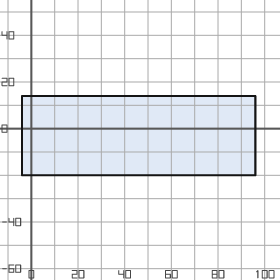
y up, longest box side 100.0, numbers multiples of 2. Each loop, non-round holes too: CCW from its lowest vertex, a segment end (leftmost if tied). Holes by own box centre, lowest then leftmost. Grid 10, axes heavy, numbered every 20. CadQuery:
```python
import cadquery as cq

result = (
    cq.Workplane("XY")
    .moveTo(-4.0, -20.0)
    .lineTo(96.0, -20.0)
    .lineTo(96.0, 14.0)
    .lineTo(-4.0, 14.0)
    .close()
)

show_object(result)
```